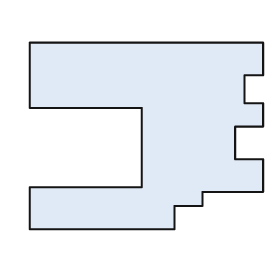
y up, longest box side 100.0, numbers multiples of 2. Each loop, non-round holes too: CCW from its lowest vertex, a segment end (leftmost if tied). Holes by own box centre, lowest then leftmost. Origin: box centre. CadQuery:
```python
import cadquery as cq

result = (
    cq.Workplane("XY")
    .moveTo(-50.0, -40.0)
    .lineTo(12.0, -40.0)
    .lineTo(12.0, -30.0)
    .lineTo(24.0, -30.0)
    .lineTo(24.0, -24.0)
    .lineTo(50.0, -24.0)
    .lineTo(50.0, -10.0)
    .lineTo(38.0, -10.0)
    .lineTo(38.0, 4.0)
    .lineTo(50.0, 4.0)
    .lineTo(50.0, 14.0)
    .lineTo(42.0, 14.0)
    .lineTo(42.0, 26.0)
    .lineTo(50.0, 26.0)
    .lineTo(50.0, 40.0)
    .lineTo(-50.0, 40.0)
    .lineTo(-50.0, 12.0)
    .lineTo(-2.0, 12.0)
    .lineTo(-2.0, -22.0)
    .lineTo(-50.0, -22.0)
    .close()
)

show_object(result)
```